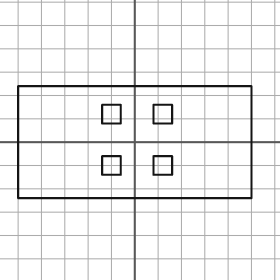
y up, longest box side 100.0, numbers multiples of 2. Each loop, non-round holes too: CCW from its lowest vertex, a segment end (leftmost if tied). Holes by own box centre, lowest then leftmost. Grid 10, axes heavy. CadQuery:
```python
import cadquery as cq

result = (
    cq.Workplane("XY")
    .moveTo(-50.0, -24.0)
    .lineTo(50.0, -24.0)
    .lineTo(50.0, 24.0)
    .lineTo(-50.0, 24.0)
    .close()
    .moveTo(-14.0, -14.0)
    .lineTo(-6.0, -14.0)
    .lineTo(-6.0, -6.0)
    .lineTo(-14.0, -6.0)
    .close()
    .moveTo(8.0, -14.0)
    .lineTo(16.0, -14.0)
    .lineTo(16.0, -6.0)
    .lineTo(8.0, -6.0)
    .close()
    .moveTo(-14.0, 8.0)
    .lineTo(-6.0, 8.0)
    .lineTo(-6.0, 16.0)
    .lineTo(-14.0, 16.0)
    .close()
    .moveTo(8.0, 8.0)
    .lineTo(16.0, 8.0)
    .lineTo(16.0, 16.0)
    .lineTo(8.0, 16.0)
    .close()
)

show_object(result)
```